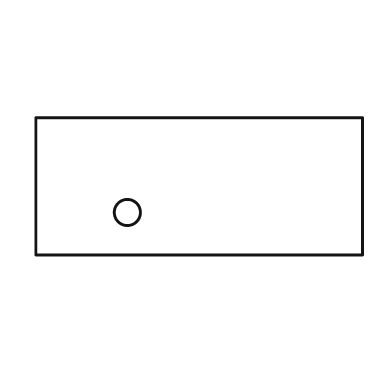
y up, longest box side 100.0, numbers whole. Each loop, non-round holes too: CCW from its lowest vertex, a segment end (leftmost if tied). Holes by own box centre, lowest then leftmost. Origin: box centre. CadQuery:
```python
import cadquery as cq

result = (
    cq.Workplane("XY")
    .moveTo(-50.0, -21.0)
    .lineTo(50.0, -21.0)
    .lineTo(50.0, 21.0)
    .lineTo(-50.0, 21.0)
    .close()
    .moveTo(-22.0, -8.0)
    .circle(4.0)
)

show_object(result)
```